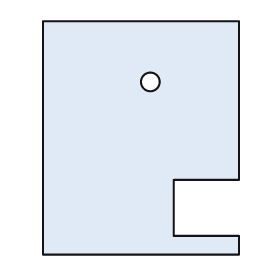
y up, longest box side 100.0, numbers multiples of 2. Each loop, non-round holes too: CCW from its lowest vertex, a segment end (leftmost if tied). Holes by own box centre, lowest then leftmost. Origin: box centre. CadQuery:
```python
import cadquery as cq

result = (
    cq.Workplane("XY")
    .moveTo(-42.0, -50.0)
    .lineTo(42.0, -50.0)
    .lineTo(42.0, -42.0)
    .lineTo(14.0, -42.0)
    .lineTo(14.0, -18.0)
    .lineTo(42.0, -18.0)
    .lineTo(42.0, 50.0)
    .lineTo(-42.0, 50.0)
    .close()
    .moveTo(4.0, 24.0)
    .circle(4.0)
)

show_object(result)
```